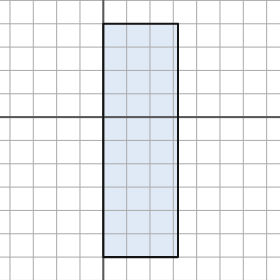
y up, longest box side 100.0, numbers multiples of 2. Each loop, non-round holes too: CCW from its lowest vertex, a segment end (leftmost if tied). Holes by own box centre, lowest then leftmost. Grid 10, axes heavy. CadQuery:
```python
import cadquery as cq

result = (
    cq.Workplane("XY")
    .moveTo(0.0, -60.0)
    .lineTo(32.0, -60.0)
    .lineTo(32.0, 40.0)
    .lineTo(0.0, 40.0)
    .close()
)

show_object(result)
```